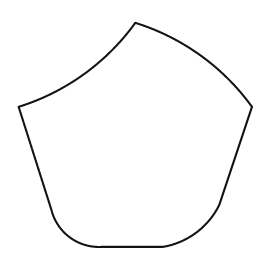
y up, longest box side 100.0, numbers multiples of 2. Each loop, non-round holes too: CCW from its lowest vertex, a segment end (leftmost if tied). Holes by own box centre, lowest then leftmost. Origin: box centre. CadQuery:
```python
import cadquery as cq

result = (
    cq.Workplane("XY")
    .moveTo(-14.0, -48.0)
    .lineTo(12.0, -48.0)
    .threePointArc((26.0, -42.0), (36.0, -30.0))
    .lineTo(50.0, 12.0)
    .threePointArc((28.0, 34.0), (0.0, 48.0))
    .threePointArc((-22.0, 26.0), (-50.0, 12.0))
    .lineTo(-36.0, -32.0)
    .threePointArc((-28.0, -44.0), (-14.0, -48.0))
    .close()
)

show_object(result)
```